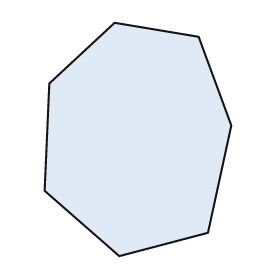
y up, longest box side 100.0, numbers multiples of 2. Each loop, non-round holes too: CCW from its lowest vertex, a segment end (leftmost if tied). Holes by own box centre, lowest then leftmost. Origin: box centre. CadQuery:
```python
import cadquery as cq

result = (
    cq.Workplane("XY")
    .moveTo(-8.0, -50.0)
    .lineTo(30.0, -40.0)
    .lineTo(40.0, 6.0)
    .lineTo(26.0, 44.0)
    .lineTo(-10.0, 50.0)
    .lineTo(-38.0, 24.0)
    .lineTo(-40.0, -22.0)
    .close()
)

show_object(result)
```